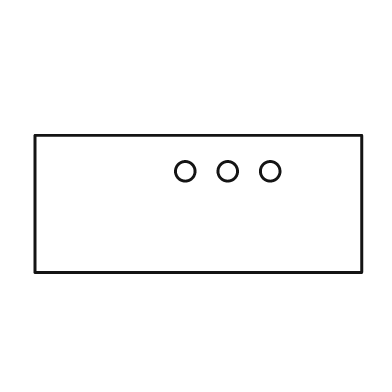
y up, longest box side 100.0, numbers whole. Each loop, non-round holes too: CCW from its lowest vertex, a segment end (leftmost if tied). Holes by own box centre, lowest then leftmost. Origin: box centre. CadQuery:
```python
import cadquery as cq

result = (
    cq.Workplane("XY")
    .moveTo(-50.0, -21.0)
    .lineTo(50.0, -21.0)
    .lineTo(50.0, 21.0)
    .lineTo(-50.0, 21.0)
    .close()
    .moveTo(-4.0, 10.0)
    .circle(3.0)
    .moveTo(9.0, 10.0)
    .circle(3.0)
    .moveTo(22.0, 10.0)
    .circle(3.0)
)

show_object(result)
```